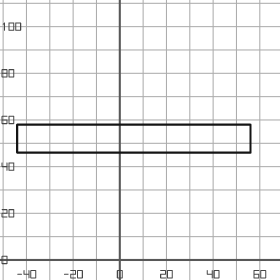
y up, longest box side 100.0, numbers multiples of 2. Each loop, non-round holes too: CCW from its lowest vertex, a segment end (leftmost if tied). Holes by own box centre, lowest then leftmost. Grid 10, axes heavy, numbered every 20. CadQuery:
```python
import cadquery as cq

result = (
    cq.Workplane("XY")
    .moveTo(-44.0, 46.0)
    .lineTo(56.0, 46.0)
    .lineTo(56.0, 58.0)
    .lineTo(-44.0, 58.0)
    .close()
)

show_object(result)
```